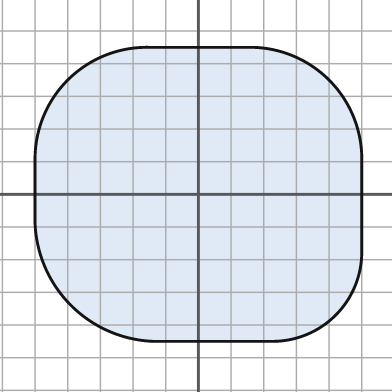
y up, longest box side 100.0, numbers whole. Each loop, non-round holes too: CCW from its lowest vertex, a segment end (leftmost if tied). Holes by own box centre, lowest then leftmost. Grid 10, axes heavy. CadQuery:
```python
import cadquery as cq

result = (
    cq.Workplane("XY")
    .moveTo(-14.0, -45.0)
    .lineTo(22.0, -45.0)
    .threePointArc((42.0, -37.0), (50.0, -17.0))
    .lineTo(50.0, 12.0)
    .threePointArc((40.0, 35.0), (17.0, 45.0))
    .lineTo(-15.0, 45.0)
    .threePointArc((-40.0, 35.0), (-50.0, 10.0))
    .lineTo(-50.0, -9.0)
    .threePointArc((-39.0, -34.0), (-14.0, -45.0))
    .close()
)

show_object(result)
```